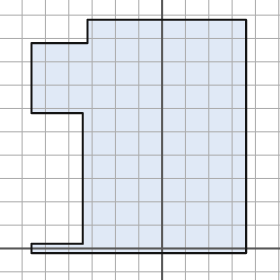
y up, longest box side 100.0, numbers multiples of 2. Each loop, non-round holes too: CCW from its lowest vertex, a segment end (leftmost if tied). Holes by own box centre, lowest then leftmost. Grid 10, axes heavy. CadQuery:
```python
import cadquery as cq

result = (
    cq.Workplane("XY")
    .moveTo(-56.0, -2.0)
    .lineTo(36.0, -2.0)
    .lineTo(36.0, 98.0)
    .lineTo(-32.0, 98.0)
    .lineTo(-32.0, 88.0)
    .lineTo(-56.0, 88.0)
    .lineTo(-56.0, 58.0)
    .lineTo(-34.0, 58.0)
    .lineTo(-34.0, 2.0)
    .lineTo(-56.0, 2.0)
    .close()
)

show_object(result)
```